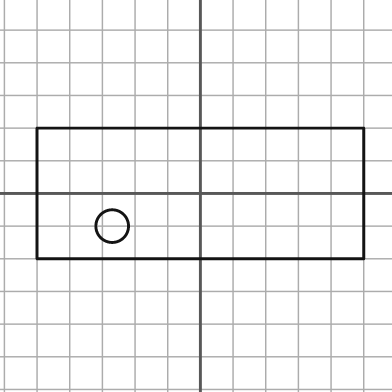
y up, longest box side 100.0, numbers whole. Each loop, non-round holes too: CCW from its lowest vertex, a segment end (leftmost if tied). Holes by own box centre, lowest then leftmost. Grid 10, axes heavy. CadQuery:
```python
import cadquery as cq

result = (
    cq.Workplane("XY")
    .moveTo(-50.0, -20.0)
    .lineTo(50.0, -20.0)
    .lineTo(50.0, 20.0)
    .lineTo(-50.0, 20.0)
    .close()
    .moveTo(-27.0, -10.0)
    .circle(5.0)
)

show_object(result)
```